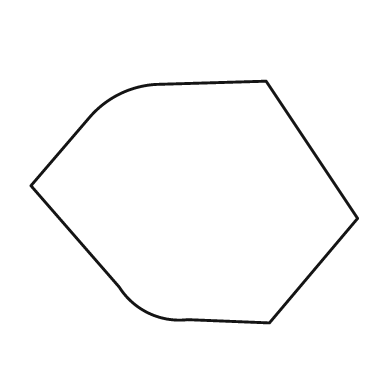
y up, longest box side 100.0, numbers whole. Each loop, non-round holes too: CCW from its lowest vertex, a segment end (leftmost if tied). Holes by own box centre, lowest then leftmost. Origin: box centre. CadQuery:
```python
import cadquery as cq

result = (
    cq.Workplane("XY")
    .moveTo(23.0, -37.0)
    .lineTo(50.0, -5.0)
    .lineTo(22.0, 37.0)
    .lineTo(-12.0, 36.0)
    .threePointArc((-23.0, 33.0), (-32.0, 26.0))
    .lineTo(-50.0, 5.0)
    .lineTo(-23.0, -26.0)
    .threePointArc((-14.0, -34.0), (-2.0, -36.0))
    .close()
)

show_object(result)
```